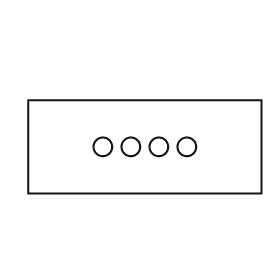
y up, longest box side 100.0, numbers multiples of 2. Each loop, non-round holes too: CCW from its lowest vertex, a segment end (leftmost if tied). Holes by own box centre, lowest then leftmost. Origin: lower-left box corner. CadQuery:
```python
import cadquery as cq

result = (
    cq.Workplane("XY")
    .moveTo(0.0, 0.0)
    .lineTo(100.0, 0.0)
    .lineTo(100.0, 40.0)
    .lineTo(0.0, 40.0)
    .close()
    .moveTo(32.0, 20.0)
    .circle(4.0)
    .moveTo(44.0, 20.0)
    .circle(4.0)
    .moveTo(56.0, 20.0)
    .circle(4.0)
    .moveTo(68.0, 20.0)
    .circle(4.0)
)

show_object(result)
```